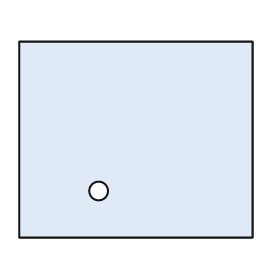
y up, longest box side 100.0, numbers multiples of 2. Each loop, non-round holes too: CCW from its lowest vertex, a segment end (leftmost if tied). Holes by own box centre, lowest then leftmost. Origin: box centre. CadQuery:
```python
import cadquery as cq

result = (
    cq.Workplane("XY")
    .moveTo(-50.0, -42.0)
    .lineTo(50.0, -42.0)
    .lineTo(50.0, 42.0)
    .lineTo(-50.0, 42.0)
    .close()
    .moveTo(-16.0, -22.0)
    .circle(4.0)
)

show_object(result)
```